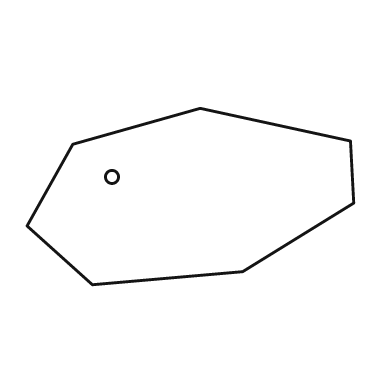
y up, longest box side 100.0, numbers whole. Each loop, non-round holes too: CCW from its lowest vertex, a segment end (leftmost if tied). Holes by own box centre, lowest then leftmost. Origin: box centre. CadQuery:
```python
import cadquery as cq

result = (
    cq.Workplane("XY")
    .moveTo(-30.0, -27.0)
    .lineTo(16.0, -23.0)
    .lineTo(50.0, -2.0)
    .lineTo(49.0, 17.0)
    .lineTo(3.0, 27.0)
    .lineTo(-36.0, 16.0)
    .lineTo(-50.0, -9.0)
    .close()
    .moveTo(-24.0, 6.0)
    .circle(2.0)
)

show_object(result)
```